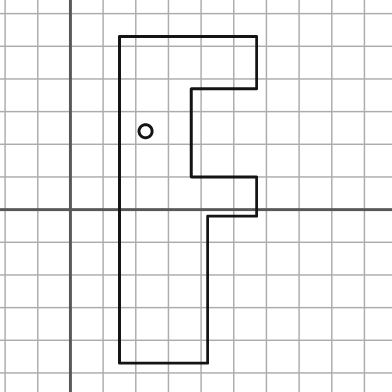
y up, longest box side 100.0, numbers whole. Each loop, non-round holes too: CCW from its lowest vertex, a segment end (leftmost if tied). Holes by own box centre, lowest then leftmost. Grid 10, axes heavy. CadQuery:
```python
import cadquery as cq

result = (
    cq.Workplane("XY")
    .moveTo(15.0, -47.0)
    .lineTo(42.0, -47.0)
    .lineTo(42.0, -2.0)
    .lineTo(57.0, -2.0)
    .lineTo(57.0, 10.0)
    .lineTo(37.0, 10.0)
    .lineTo(37.0, 37.0)
    .lineTo(57.0, 37.0)
    .lineTo(57.0, 53.0)
    .lineTo(15.0, 53.0)
    .close()
    .moveTo(23.0, 24.0)
    .circle(2.0)
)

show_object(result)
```